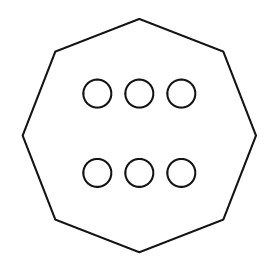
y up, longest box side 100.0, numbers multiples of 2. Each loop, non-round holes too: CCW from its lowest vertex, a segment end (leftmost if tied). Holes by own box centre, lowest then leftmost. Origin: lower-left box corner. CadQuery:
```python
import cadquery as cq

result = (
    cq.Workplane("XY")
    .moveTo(50.0, 0.0)
    .lineTo(86.0, 14.0)
    .lineTo(100.0, 50.0)
    .lineTo(86.0, 86.0)
    .lineTo(50.0, 100.0)
    .lineTo(14.0, 86.0)
    .lineTo(0.0, 50.0)
    .lineTo(14.0, 14.0)
    .close()
    .moveTo(32.0, 34.0)
    .circle(6.0)
    .moveTo(50.0, 34.0)
    .circle(6.0)
    .moveTo(68.0, 34.0)
    .circle(6.0)
    .moveTo(32.0, 68.0)
    .circle(6.0)
    .moveTo(50.0, 68.0)
    .circle(6.0)
    .moveTo(68.0, 68.0)
    .circle(6.0)
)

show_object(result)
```